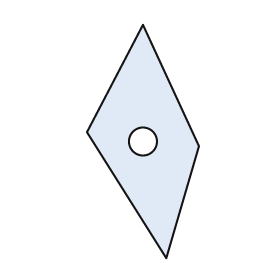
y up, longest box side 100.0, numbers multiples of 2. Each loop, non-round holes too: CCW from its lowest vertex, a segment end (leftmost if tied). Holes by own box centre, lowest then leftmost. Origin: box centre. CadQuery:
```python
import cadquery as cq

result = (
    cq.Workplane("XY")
    .moveTo(10.0, -50.0)
    .lineTo(24.0, -2.0)
    .lineTo(0.0, 50.0)
    .lineTo(-24.0, 4.0)
    .close()
    .moveTo(0.0, 0.0)
    .circle(6.0)
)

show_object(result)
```